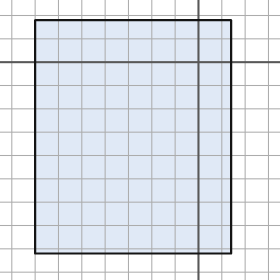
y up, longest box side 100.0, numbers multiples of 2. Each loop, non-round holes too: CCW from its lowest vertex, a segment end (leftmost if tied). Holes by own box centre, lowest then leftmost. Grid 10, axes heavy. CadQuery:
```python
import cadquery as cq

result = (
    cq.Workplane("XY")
    .moveTo(-70.0, -82.0)
    .lineTo(14.0, -82.0)
    .lineTo(14.0, 18.0)
    .lineTo(-70.0, 18.0)
    .close()
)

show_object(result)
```